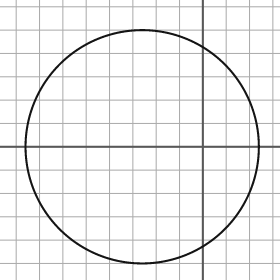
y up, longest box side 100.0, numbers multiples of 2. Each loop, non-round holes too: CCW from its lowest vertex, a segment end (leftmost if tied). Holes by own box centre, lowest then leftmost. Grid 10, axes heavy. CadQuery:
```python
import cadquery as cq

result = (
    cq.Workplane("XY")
    .moveTo(-26.0, 0.0)
    .circle(50.0)
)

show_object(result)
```